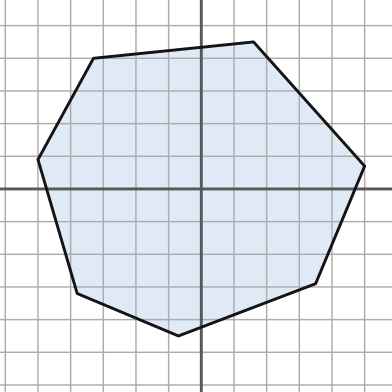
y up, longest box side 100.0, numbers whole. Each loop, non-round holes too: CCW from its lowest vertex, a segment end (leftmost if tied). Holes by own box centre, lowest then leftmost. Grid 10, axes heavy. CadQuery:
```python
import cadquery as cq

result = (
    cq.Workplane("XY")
    .moveTo(-7.0, -45.0)
    .lineTo(35.0, -29.0)
    .lineTo(50.0, 7.0)
    .lineTo(16.0, 45.0)
    .lineTo(-33.0, 40.0)
    .lineTo(-50.0, 9.0)
    .lineTo(-38.0, -32.0)
    .close()
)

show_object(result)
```